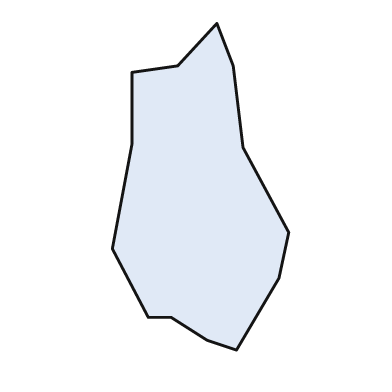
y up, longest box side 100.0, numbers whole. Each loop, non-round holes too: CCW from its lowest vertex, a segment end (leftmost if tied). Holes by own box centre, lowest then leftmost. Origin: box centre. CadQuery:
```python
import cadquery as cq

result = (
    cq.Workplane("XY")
    .moveTo(11.0, -50.0)
    .lineTo(24.0, -28.0)
    .lineTo(27.0, -14.0)
    .lineTo(13.0, 12.0)
    .lineTo(10.0, 37.0)
    .lineTo(5.0, 50.0)
    .lineTo(-7.0, 37.0)
    .lineTo(-21.0, 35.0)
    .lineTo(-21.0, 13.0)
    .lineTo(-27.0, -19.0)
    .lineTo(-16.0, -40.0)
    .lineTo(-9.0, -40.0)
    .lineTo(2.0, -47.0)
    .close()
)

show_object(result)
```